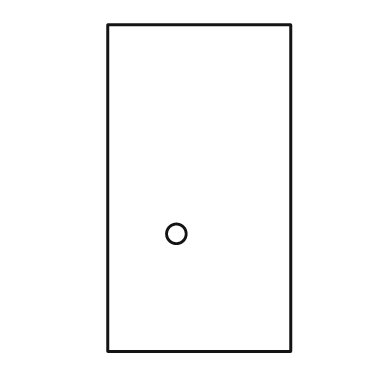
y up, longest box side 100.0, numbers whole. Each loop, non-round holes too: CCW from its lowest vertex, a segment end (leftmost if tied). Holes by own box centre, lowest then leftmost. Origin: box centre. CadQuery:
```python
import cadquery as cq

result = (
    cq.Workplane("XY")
    .moveTo(-28.0, -50.0)
    .lineTo(28.0, -50.0)
    .lineTo(28.0, 50.0)
    .lineTo(-28.0, 50.0)
    .close()
    .moveTo(-7.0, -14.0)
    .circle(3.0)
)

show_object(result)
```